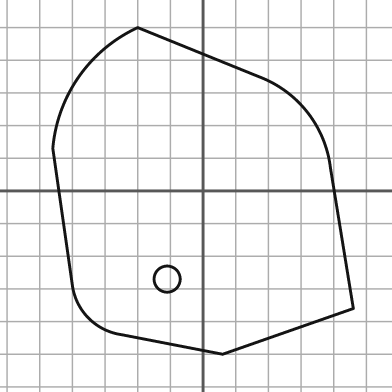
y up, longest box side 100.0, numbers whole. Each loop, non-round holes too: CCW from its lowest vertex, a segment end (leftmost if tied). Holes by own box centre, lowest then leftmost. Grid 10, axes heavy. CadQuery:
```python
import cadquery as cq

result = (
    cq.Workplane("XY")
    .moveTo(6.0, -50.0)
    .lineTo(46.0, -36.0)
    .lineTo(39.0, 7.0)
    .threePointArc((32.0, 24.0), (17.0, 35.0))
    .lineTo(-20.0, 50.0)
    .threePointArc((-38.0, 35.0), (-46.0, 13.0))
    .lineTo(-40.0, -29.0)
    .threePointArc((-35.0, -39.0), (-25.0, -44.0))
    .close()
    .moveTo(-11.0, -27.0)
    .circle(4.0)
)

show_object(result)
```